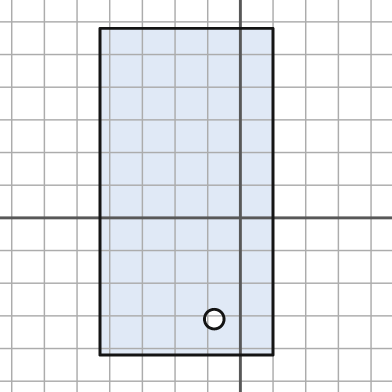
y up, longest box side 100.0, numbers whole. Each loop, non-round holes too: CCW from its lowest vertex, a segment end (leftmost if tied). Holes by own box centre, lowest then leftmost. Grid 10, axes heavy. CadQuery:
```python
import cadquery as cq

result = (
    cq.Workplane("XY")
    .moveTo(-43.0, -42.0)
    .lineTo(10.0, -42.0)
    .lineTo(10.0, 58.0)
    .lineTo(-43.0, 58.0)
    .close()
    .moveTo(-8.0, -31.0)
    .circle(3.0)
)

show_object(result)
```